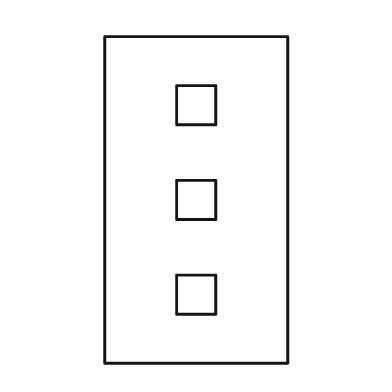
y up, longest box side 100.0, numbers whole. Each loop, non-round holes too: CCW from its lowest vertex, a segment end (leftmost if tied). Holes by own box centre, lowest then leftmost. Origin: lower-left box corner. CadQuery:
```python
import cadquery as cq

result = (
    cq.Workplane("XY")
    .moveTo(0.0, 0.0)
    .lineTo(56.0, 0.0)
    .lineTo(56.0, 100.0)
    .lineTo(0.0, 100.0)
    .close()
    .moveTo(22.0, 15.0)
    .lineTo(34.0, 15.0)
    .lineTo(34.0, 27.0)
    .lineTo(22.0, 27.0)
    .close()
    .moveTo(22.0, 44.0)
    .lineTo(34.0, 44.0)
    .lineTo(34.0, 56.0)
    .lineTo(22.0, 56.0)
    .close()
    .moveTo(22.0, 73.0)
    .lineTo(34.0, 73.0)
    .lineTo(34.0, 85.0)
    .lineTo(22.0, 85.0)
    .close()
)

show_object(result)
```